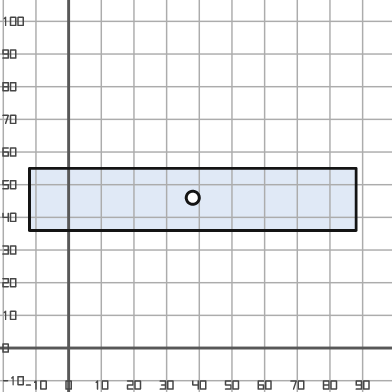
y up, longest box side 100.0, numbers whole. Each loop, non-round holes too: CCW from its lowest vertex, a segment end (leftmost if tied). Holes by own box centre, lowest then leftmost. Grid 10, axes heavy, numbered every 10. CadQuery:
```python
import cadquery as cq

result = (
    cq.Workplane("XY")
    .moveTo(-12.0, 36.0)
    .lineTo(88.0, 36.0)
    .lineTo(88.0, 55.0)
    .lineTo(-12.0, 55.0)
    .close()
    .moveTo(38.0, 46.0)
    .circle(2.0)
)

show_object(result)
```